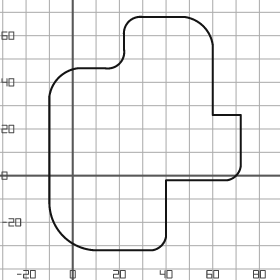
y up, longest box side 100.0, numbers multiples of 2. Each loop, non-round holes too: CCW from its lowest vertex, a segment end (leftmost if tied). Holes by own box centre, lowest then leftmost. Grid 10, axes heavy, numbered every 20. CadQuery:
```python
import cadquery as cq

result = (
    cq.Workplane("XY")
    .moveTo(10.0, -32.0)
    .lineTo(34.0, -32.0)
    .threePointArc((38.0, -30.0), (40.0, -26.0))
    .lineTo(40.0, -2.0)
    .lineTo(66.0, -2.0)
    .threePointArc((70.0, 0.0), (72.0, 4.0))
    .lineTo(72.0, 26.0)
    .lineTo(60.0, 26.0)
    .lineTo(60.0, 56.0)
    .threePointArc((56.0, 64.0), (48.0, 68.0))
    .lineTo(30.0, 68.0)
    .threePointArc((24.0, 66.0), (22.0, 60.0))
    .lineTo(22.0, 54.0)
    .threePointArc((20.0, 48.0), (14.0, 46.0))
    .lineTo(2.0, 46.0)
    .threePointArc((-6.0, 42.0), (-10.0, 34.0))
    .lineTo(-10.0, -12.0)
    .threePointArc((-4.0, -26.0), (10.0, -32.0))
    .close()
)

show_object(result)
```